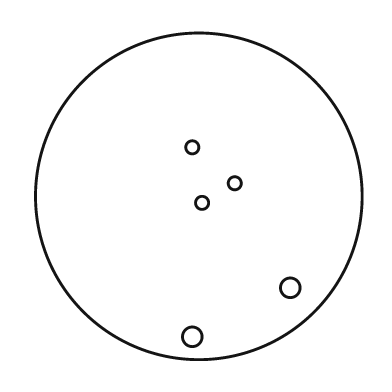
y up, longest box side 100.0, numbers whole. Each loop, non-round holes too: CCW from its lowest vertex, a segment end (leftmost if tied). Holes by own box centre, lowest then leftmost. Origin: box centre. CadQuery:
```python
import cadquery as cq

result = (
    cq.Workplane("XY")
    .moveTo(0.0, 0.0)
    .circle(50.0)
    .moveTo(-2.0, -43.0)
    .circle(3.0)
    .moveTo(28.0, -28.0)
    .circle(3.0)
    .moveTo(1.0, -2.0)
    .circle(2.0)
    .moveTo(11.0, 4.0)
    .circle(2.0)
    .moveTo(-2.0, 15.0)
    .circle(2.0)
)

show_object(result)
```